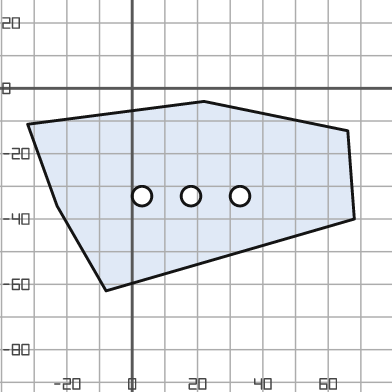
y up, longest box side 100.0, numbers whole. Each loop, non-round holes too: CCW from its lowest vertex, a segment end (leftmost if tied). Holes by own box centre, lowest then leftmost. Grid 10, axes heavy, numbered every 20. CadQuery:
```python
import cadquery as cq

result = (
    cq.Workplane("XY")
    .moveTo(-8.0, -62.0)
    .lineTo(68.0, -40.0)
    .lineTo(66.0, -13.0)
    .lineTo(22.0, -4.0)
    .lineTo(-32.0, -11.0)
    .lineTo(-23.0, -36.0)
    .close()
    .moveTo(3.0, -33.0)
    .circle(3.0)
    .moveTo(18.0, -33.0)
    .circle(3.0)
    .moveTo(33.0, -33.0)
    .circle(3.0)
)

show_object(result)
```